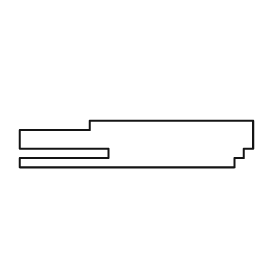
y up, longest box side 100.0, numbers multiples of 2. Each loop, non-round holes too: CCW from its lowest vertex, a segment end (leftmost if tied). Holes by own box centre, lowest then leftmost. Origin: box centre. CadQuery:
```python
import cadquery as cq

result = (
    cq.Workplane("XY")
    .moveTo(-50.0, -10.0)
    .lineTo(42.0, -10.0)
    .lineTo(42.0, -6.0)
    .lineTo(46.0, -6.0)
    .lineTo(46.0, -2.0)
    .lineTo(50.0, -2.0)
    .lineTo(50.0, 10.0)
    .lineTo(-20.0, 10.0)
    .lineTo(-20.0, 6.0)
    .lineTo(-50.0, 6.0)
    .lineTo(-50.0, -2.0)
    .lineTo(-12.0, -2.0)
    .lineTo(-12.0, -6.0)
    .lineTo(-50.0, -6.0)
    .close()
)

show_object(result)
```